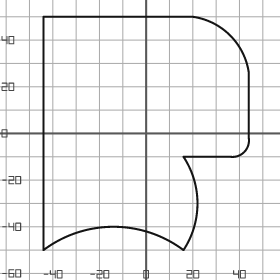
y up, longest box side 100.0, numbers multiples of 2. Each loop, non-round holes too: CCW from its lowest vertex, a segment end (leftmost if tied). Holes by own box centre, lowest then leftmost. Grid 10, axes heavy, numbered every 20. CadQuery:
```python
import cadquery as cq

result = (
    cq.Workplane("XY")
    .moveTo(-44.0, -50.0)
    .threePointArc((-14.0, -40.0), (16.0, -50.0))
    .threePointArc((22.0, -30.0), (16.0, -10.0))
    .lineTo(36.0, -10.0)
    .threePointArc((42.0, -8.0), (44.0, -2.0))
    .lineTo(44.0, 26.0)
    .threePointArc((36.0, 42.0), (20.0, 50.0))
    .lineTo(-44.0, 50.0)
    .close()
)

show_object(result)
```